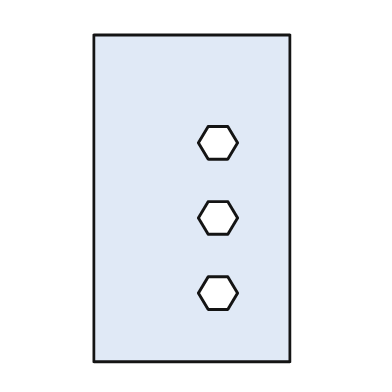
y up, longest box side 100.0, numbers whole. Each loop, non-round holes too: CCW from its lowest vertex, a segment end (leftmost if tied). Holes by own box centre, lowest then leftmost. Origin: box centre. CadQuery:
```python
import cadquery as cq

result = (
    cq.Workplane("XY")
    .moveTo(-30.0, -50.0)
    .lineTo(30.0, -50.0)
    .lineTo(30.0, 50.0)
    .lineTo(-30.0, 50.0)
    .close()
    .moveTo(5.0, -34.0)
    .lineTo(11.0, -34.0)
    .lineTo(14.0, -29.0)
    .lineTo(11.0, -24.0)
    .lineTo(5.0, -24.0)
    .lineTo(2.0, -29.0)
    .close()
    .moveTo(5.0, -11.0)
    .lineTo(11.0, -11.0)
    .lineTo(14.0, -6.0)
    .lineTo(11.0, -1.0)
    .lineTo(5.0, -1.0)
    .lineTo(2.0, -6.0)
    .close()
    .moveTo(5.0, 12.0)
    .lineTo(11.0, 12.0)
    .lineTo(14.0, 17.0)
    .lineTo(11.0, 22.0)
    .lineTo(5.0, 22.0)
    .lineTo(2.0, 17.0)
    .close()
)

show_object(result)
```